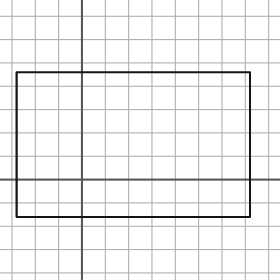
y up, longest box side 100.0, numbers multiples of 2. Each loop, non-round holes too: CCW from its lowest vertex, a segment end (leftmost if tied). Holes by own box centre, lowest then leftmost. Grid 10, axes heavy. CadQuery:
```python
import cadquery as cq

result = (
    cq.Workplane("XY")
    .moveTo(-28.0, -16.0)
    .lineTo(72.0, -16.0)
    .lineTo(72.0, 46.0)
    .lineTo(-28.0, 46.0)
    .close()
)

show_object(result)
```